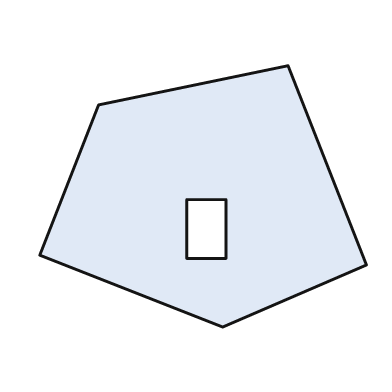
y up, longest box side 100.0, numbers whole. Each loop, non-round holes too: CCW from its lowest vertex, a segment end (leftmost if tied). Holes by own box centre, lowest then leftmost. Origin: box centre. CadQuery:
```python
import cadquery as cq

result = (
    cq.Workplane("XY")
    .moveTo(6.0, -40.0)
    .lineTo(50.0, -21.0)
    .lineTo(26.0, 40.0)
    .lineTo(-32.0, 28.0)
    .lineTo(-50.0, -18.0)
    .close()
    .moveTo(-5.0, -19.0)
    .lineTo(7.0, -19.0)
    .lineTo(7.0, -1.0)
    .lineTo(-5.0, -1.0)
    .close()
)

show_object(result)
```